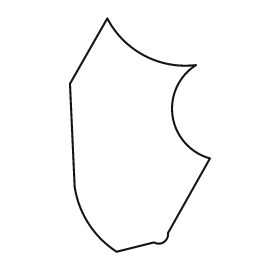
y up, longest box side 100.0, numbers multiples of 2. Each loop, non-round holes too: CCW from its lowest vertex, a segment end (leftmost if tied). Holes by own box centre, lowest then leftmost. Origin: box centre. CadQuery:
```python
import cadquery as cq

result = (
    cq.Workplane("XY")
    .moveTo(-10.0, -50.0)
    .lineTo(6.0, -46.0)
    .threePointArc((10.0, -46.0), (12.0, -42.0))
    .lineTo(30.0, -10.0)
    .threePointArc((14.0, 8.0), (24.0, 30.0))
    .threePointArc((2.0, 34.0), (-14.0, 50.0))
    .lineTo(-30.0, 22.0)
    .lineTo(-28.0, -22.0)
    .threePointArc((-22.0, -38.0), (-10.0, -50.0))
    .close()
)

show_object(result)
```